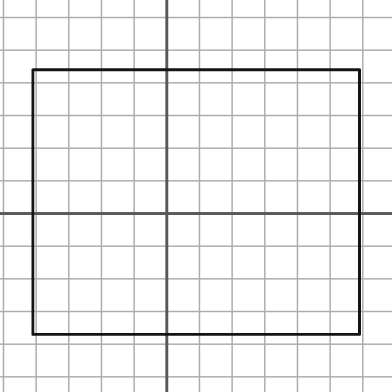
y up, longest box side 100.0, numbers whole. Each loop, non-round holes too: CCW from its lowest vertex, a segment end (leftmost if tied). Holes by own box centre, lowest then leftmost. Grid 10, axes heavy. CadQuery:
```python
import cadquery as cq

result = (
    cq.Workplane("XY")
    .moveTo(-41.0, -37.0)
    .lineTo(59.0, -37.0)
    .lineTo(59.0, 44.0)
    .lineTo(-41.0, 44.0)
    .close()
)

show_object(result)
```